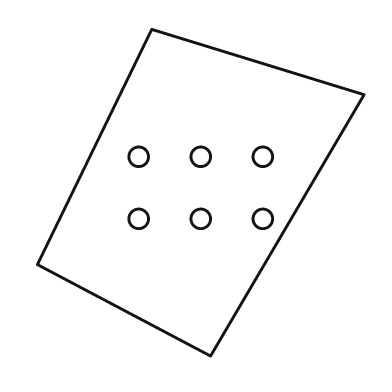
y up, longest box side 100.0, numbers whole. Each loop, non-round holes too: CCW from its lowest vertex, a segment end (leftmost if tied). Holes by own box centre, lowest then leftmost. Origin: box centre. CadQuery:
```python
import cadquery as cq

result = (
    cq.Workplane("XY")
    .moveTo(3.0, -50.0)
    .lineTo(50.0, 30.0)
    .lineTo(-15.0, 50.0)
    .lineTo(-50.0, -22.0)
    .close()
    .moveTo(-19.0, -8.0)
    .circle(3.0)
    .moveTo(0.0, -8.0)
    .circle(3.0)
    .moveTo(19.0, -8.0)
    .circle(3.0)
    .moveTo(-19.0, 11.0)
    .circle(3.0)
    .moveTo(0.0, 11.0)
    .circle(3.0)
    .moveTo(19.0, 11.0)
    .circle(3.0)
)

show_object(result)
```